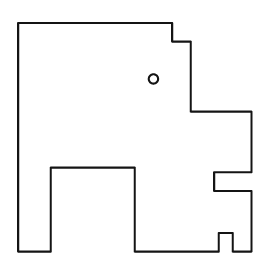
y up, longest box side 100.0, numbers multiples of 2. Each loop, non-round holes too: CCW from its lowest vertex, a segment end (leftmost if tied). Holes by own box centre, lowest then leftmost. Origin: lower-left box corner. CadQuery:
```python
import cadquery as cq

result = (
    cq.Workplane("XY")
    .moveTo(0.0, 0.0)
    .lineTo(14.0, 0.0)
    .lineTo(14.0, 36.0)
    .lineTo(50.0, 36.0)
    .lineTo(50.0, 0.0)
    .lineTo(86.0, 0.0)
    .lineTo(86.0, 8.0)
    .lineTo(92.0, 8.0)
    .lineTo(92.0, 0.0)
    .lineTo(100.0, 0.0)
    .lineTo(100.0, 26.0)
    .lineTo(84.0, 26.0)
    .lineTo(84.0, 34.0)
    .lineTo(100.0, 34.0)
    .lineTo(100.0, 60.0)
    .lineTo(74.0, 60.0)
    .lineTo(74.0, 90.0)
    .lineTo(66.0, 90.0)
    .lineTo(66.0, 98.0)
    .lineTo(0.0, 98.0)
    .close()
    .moveTo(58.0, 74.0)
    .circle(2.0)
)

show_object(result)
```